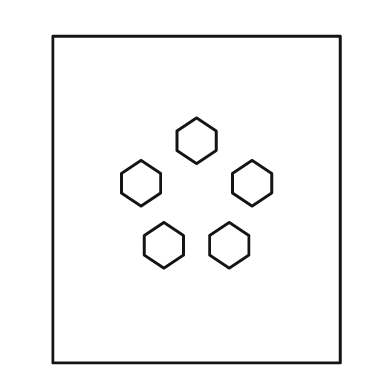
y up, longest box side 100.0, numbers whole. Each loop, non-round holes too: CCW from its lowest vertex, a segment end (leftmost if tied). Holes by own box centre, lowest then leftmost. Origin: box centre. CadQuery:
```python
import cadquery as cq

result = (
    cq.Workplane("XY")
    .moveTo(-44.0, -50.0)
    .lineTo(44.0, -50.0)
    .lineTo(44.0, 50.0)
    .lineTo(-44.0, 50.0)
    .close()
    .moveTo(-10.0, -21.0)
    .lineTo(-4.0, -17.0)
    .lineTo(-4.0, -11.0)
    .lineTo(-10.0, -7.0)
    .lineTo(-16.0, -11.0)
    .lineTo(-16.0, -17.0)
    .close()
    .moveTo(10.0, -21.0)
    .lineTo(16.0, -17.0)
    .lineTo(16.0, -11.0)
    .lineTo(10.0, -7.0)
    .lineTo(4.0, -11.0)
    .lineTo(4.0, -17.0)
    .close()
    .moveTo(-17.0, -2.0)
    .lineTo(-11.0, 2.0)
    .lineTo(-11.0, 8.0)
    .lineTo(-17.0, 12.0)
    .lineTo(-23.0, 8.0)
    .lineTo(-23.0, 2.0)
    .close()
    .moveTo(17.0, -2.0)
    .lineTo(23.0, 2.0)
    .lineTo(23.0, 8.0)
    .lineTo(17.0, 12.0)
    .lineTo(11.0, 8.0)
    .lineTo(11.0, 2.0)
    .close()
    .moveTo(0.0, 11.0)
    .lineTo(6.0, 15.0)
    .lineTo(6.0, 21.0)
    .lineTo(0.0, 25.0)
    .lineTo(-6.0, 21.0)
    .lineTo(-6.0, 15.0)
    .close()
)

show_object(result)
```